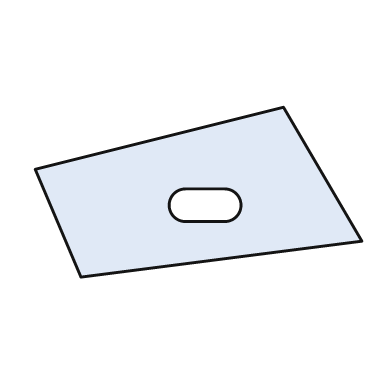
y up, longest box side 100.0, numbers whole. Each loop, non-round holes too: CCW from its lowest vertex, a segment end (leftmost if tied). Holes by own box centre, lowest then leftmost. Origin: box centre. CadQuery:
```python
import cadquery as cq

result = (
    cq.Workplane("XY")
    .moveTo(-36.0, -26.0)
    .lineTo(50.0, -15.0)
    .lineTo(26.0, 26.0)
    .lineTo(-50.0, 7.0)
    .close()
    .moveTo(-4.0, -9.0)
    .lineTo(8.0, -9.0)
    .threePointArc((13.0, -4.0), (8.0, 1.0))
    .lineTo(-4.0, 1.0)
    .threePointArc((-9.0, -4.0), (-4.0, -9.0))
    .close()
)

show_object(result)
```